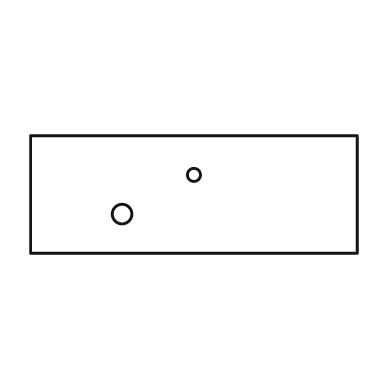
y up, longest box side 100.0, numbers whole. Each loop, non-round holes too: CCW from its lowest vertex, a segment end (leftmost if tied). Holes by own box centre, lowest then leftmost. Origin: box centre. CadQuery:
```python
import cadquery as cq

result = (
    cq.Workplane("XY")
    .moveTo(-50.0, -18.0)
    .lineTo(50.0, -18.0)
    .lineTo(50.0, 18.0)
    .lineTo(-50.0, 18.0)
    .close()
    .moveTo(-22.0, -6.0)
    .circle(3.0)
    .moveTo(0.0, 6.0)
    .circle(2.0)
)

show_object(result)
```